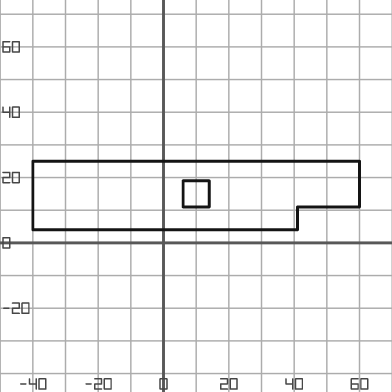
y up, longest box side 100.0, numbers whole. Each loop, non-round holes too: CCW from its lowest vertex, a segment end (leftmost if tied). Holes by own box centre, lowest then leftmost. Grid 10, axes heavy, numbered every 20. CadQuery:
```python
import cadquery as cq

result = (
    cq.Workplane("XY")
    .moveTo(-40.0, 4.0)
    .lineTo(41.0, 4.0)
    .lineTo(41.0, 11.0)
    .lineTo(60.0, 11.0)
    .lineTo(60.0, 25.0)
    .lineTo(-40.0, 25.0)
    .close()
    .moveTo(6.0, 11.0)
    .lineTo(14.0, 11.0)
    .lineTo(14.0, 19.0)
    .lineTo(6.0, 19.0)
    .close()
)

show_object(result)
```